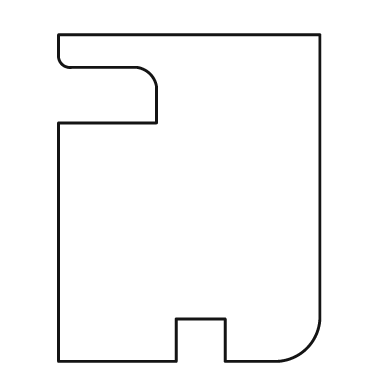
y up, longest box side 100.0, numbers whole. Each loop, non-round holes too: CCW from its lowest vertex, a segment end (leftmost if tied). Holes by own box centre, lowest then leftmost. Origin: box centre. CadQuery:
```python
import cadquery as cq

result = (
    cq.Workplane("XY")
    .moveTo(-40.0, -50.0)
    .lineTo(-4.0, -50.0)
    .lineTo(-4.0, -37.0)
    .lineTo(11.0, -37.0)
    .lineTo(11.0, -50.0)
    .lineTo(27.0, -50.0)
    .threePointArc((36.0, -46.0), (40.0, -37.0))
    .lineTo(40.0, 50.0)
    .lineTo(-40.0, 50.0)
    .lineTo(-40.0, 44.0)
    .threePointArc((-39.0, 41.0), (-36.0, 40.0))
    .lineTo(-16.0, 40.0)
    .threePointArc((-12.0, 38.0), (-10.0, 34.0))
    .lineTo(-10.0, 23.0)
    .lineTo(-40.0, 23.0)
    .close()
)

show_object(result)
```